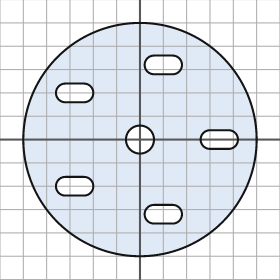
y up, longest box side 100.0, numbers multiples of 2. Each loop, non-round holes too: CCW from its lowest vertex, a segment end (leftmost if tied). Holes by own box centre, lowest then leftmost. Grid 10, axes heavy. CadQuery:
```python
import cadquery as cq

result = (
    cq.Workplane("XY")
    .moveTo(0.0, 0.0)
    .circle(50.0)
    .moveTo(6.0, -36.0)
    .lineTo(14.0, -36.0)
    .threePointArc((18.0, -32.0), (14.0, -28.0))
    .lineTo(6.0, -28.0)
    .threePointArc((2.0, -32.0), (6.0, -36.0))
    .close()
    .moveTo(-32.0, -24.0)
    .lineTo(-24.0, -24.0)
    .threePointArc((-20.0, -20.0), (-24.0, -16.0))
    .lineTo(-32.0, -16.0)
    .threePointArc((-36.0, -20.0), (-32.0, -24.0))
    .close()
    .moveTo(0.0, 0.0)
    .circle(6.0)
    .moveTo(30.0, -4.0)
    .lineTo(38.0, -4.0)
    .threePointArc((42.0, 0.0), (38.0, 4.0))
    .lineTo(30.0, 4.0)
    .threePointArc((26.0, 0.0), (30.0, -4.0))
    .close()
    .moveTo(-32.0, 16.0)
    .lineTo(-24.0, 16.0)
    .threePointArc((-20.0, 20.0), (-24.0, 24.0))
    .lineTo(-32.0, 24.0)
    .threePointArc((-36.0, 20.0), (-32.0, 16.0))
    .close()
    .moveTo(6.0, 28.0)
    .lineTo(14.0, 28.0)
    .threePointArc((18.0, 32.0), (14.0, 36.0))
    .lineTo(6.0, 36.0)
    .threePointArc((2.0, 32.0), (6.0, 28.0))
    .close()
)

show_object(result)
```